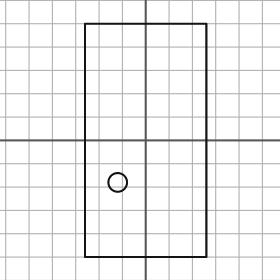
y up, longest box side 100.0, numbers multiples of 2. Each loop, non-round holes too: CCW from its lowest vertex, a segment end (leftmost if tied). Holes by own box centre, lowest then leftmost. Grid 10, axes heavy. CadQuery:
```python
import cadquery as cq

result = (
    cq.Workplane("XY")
    .moveTo(-26.0, -50.0)
    .lineTo(26.0, -50.0)
    .lineTo(26.0, 50.0)
    .lineTo(-26.0, 50.0)
    .close()
    .moveTo(-12.0, -18.0)
    .circle(4.0)
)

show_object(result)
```